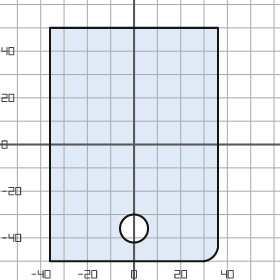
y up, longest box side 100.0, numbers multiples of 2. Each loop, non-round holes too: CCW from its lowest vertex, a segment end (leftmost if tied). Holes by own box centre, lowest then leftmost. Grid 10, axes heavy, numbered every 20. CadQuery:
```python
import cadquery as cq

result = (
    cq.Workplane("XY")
    .moveTo(-36.0, -50.0)
    .lineTo(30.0, -50.0)
    .threePointArc((34.0, -48.0), (36.0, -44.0))
    .lineTo(36.0, 50.0)
    .lineTo(-36.0, 50.0)
    .close()
    .moveTo(0.0, -36.0)
    .circle(6.0)
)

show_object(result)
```